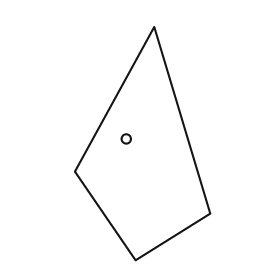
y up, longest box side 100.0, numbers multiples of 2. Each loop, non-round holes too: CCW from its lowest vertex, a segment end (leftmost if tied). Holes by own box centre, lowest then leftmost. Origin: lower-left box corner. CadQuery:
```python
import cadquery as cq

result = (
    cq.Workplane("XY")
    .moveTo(26.0, 0.0)
    .lineTo(58.0, 20.0)
    .lineTo(34.0, 100.0)
    .lineTo(0.0, 38.0)
    .close()
    .moveTo(22.0, 52.0)
    .circle(2.0)
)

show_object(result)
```